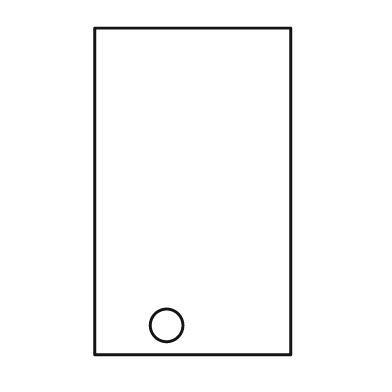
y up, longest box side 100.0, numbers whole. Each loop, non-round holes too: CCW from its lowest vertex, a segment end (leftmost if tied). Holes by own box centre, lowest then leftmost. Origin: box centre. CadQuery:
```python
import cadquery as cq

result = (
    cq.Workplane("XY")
    .moveTo(-30.0, -50.0)
    .lineTo(30.0, -50.0)
    .lineTo(30.0, 50.0)
    .lineTo(-30.0, 50.0)
    .close()
    .moveTo(-8.0, -41.0)
    .circle(5.0)
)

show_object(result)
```